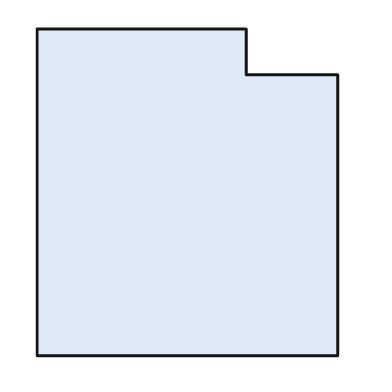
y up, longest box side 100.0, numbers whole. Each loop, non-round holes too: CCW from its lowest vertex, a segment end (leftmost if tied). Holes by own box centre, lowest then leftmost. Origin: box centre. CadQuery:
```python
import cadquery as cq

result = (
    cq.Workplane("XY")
    .moveTo(-46.0, -50.0)
    .lineTo(46.0, -50.0)
    .lineTo(46.0, 36.0)
    .lineTo(18.0, 36.0)
    .lineTo(18.0, 50.0)
    .lineTo(-46.0, 50.0)
    .close()
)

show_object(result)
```